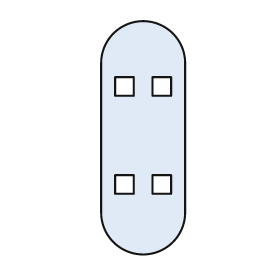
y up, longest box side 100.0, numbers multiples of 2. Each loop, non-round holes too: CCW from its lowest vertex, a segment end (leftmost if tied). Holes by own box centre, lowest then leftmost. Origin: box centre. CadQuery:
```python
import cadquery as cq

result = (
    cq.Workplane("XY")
    .moveTo(-18.0, -32.0)
    .threePointArc((0.0, -50.0), (18.0, -32.0))
    .lineTo(18.0, 32.0)
    .threePointArc((0.0, 50.0), (-18.0, 32.0))
    .close()
    .moveTo(-12.0, -24.0)
    .lineTo(-4.0, -24.0)
    .lineTo(-4.0, -16.0)
    .lineTo(-12.0, -16.0)
    .close()
    .moveTo(4.0, -24.0)
    .lineTo(12.0, -24.0)
    .lineTo(12.0, -16.0)
    .lineTo(4.0, -16.0)
    .close()
    .moveTo(-12.0, 18.0)
    .lineTo(-4.0, 18.0)
    .lineTo(-4.0, 26.0)
    .lineTo(-12.0, 26.0)
    .close()
    .moveTo(4.0, 18.0)
    .lineTo(12.0, 18.0)
    .lineTo(12.0, 26.0)
    .lineTo(4.0, 26.0)
    .close()
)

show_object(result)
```